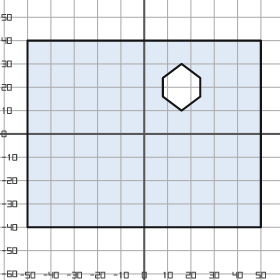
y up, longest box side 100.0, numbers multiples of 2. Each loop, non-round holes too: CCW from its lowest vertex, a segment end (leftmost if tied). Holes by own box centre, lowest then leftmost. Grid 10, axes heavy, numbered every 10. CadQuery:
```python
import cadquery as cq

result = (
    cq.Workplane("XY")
    .moveTo(-50.0, -40.0)
    .lineTo(50.0, -40.0)
    .lineTo(50.0, 40.0)
    .lineTo(-50.0, 40.0)
    .close()
    .moveTo(16.0, 10.0)
    .lineTo(24.0, 16.0)
    .lineTo(24.0, 24.0)
    .lineTo(16.0, 30.0)
    .lineTo(8.0, 24.0)
    .lineTo(8.0, 16.0)
    .close()
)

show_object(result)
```